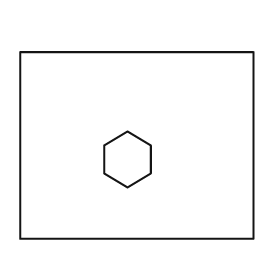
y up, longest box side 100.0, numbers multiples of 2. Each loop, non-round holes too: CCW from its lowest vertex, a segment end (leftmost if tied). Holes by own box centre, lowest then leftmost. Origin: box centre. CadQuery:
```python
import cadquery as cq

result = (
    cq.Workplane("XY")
    .moveTo(-50.0, -40.0)
    .lineTo(50.0, -40.0)
    .lineTo(50.0, 40.0)
    .lineTo(-50.0, 40.0)
    .close()
    .moveTo(-4.0, -18.0)
    .lineTo(6.0, -12.0)
    .lineTo(6.0, 0.0)
    .lineTo(-4.0, 6.0)
    .lineTo(-14.0, 0.0)
    .lineTo(-14.0, -12.0)
    .close()
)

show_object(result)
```